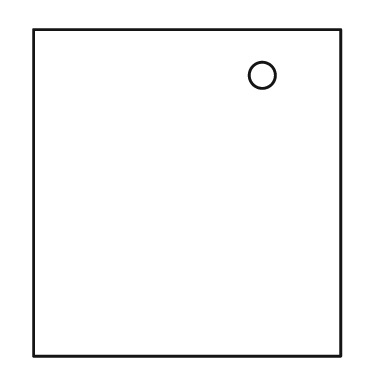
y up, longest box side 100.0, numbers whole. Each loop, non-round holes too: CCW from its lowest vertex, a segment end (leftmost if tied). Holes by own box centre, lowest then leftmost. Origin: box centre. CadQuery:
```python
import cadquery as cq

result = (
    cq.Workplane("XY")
    .moveTo(-47.0, -50.0)
    .lineTo(47.0, -50.0)
    .lineTo(47.0, 50.0)
    .lineTo(-47.0, 50.0)
    .close()
    .moveTo(23.0, 36.0)
    .circle(4.0)
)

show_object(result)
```